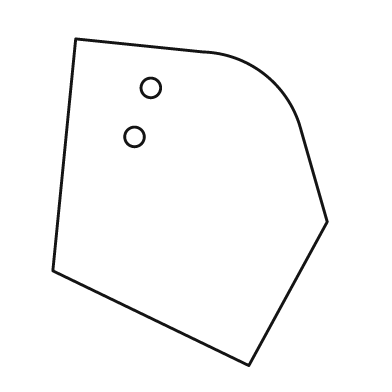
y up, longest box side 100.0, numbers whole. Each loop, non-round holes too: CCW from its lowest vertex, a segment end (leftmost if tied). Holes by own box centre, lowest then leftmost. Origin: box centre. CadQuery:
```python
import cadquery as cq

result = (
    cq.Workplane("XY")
    .moveTo(18.0, -50.0)
    .lineTo(42.0, -6.0)
    .lineTo(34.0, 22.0)
    .threePointArc((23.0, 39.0), (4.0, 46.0))
    .lineTo(-35.0, 50.0)
    .lineTo(-42.0, -21.0)
    .close()
    .moveTo(-17.0, 20.0)
    .circle(3.0)
    .moveTo(-12.0, 35.0)
    .circle(3.0)
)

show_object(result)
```